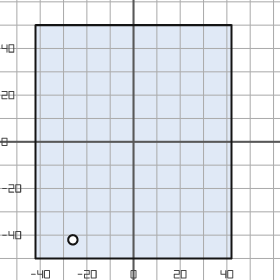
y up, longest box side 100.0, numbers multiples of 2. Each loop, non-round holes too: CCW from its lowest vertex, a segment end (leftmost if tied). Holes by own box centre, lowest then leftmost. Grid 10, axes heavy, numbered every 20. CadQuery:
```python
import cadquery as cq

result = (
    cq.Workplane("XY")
    .moveTo(-42.0, -50.0)
    .lineTo(42.0, -50.0)
    .lineTo(42.0, 50.0)
    .lineTo(-42.0, 50.0)
    .close()
    .moveTo(-26.0, -42.0)
    .circle(2.0)
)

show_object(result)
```